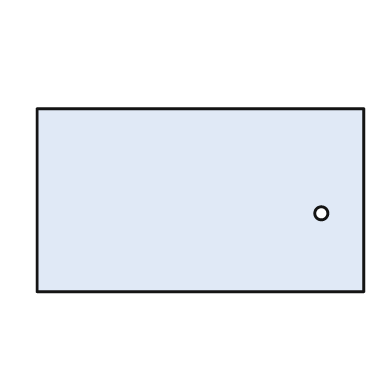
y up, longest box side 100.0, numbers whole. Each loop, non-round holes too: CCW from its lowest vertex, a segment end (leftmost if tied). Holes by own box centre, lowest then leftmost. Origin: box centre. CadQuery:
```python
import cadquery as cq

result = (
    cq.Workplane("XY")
    .moveTo(-50.0, -28.0)
    .lineTo(50.0, -28.0)
    .lineTo(50.0, 28.0)
    .lineTo(-50.0, 28.0)
    .close()
    .moveTo(37.0, -4.0)
    .circle(2.0)
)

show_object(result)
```